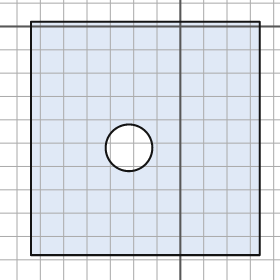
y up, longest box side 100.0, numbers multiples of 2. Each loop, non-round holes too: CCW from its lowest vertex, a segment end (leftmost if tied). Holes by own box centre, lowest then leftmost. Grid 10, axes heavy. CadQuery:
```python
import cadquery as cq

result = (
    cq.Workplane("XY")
    .moveTo(-64.0, -98.0)
    .lineTo(34.0, -98.0)
    .lineTo(34.0, 2.0)
    .lineTo(-64.0, 2.0)
    .close()
    .moveTo(-22.0, -52.0)
    .circle(10.0)
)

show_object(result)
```